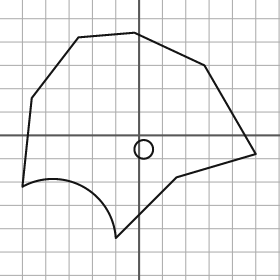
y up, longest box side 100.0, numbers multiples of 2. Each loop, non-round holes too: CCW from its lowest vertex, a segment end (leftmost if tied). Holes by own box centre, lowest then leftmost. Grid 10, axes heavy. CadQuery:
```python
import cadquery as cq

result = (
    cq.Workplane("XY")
    .moveTo(-10.0, -44.0)
    .lineTo(16.0, -18.0)
    .lineTo(50.0, -8.0)
    .lineTo(28.0, 30.0)
    .lineTo(-2.0, 44.0)
    .lineTo(-26.0, 42.0)
    .lineTo(-46.0, 16.0)
    .lineTo(-50.0, -22.0)
    .threePointArc((-24.0, -22.0), (-10.0, -44.0))
    .close()
    .moveTo(2.0, -6.0)
    .circle(4.0)
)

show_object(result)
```